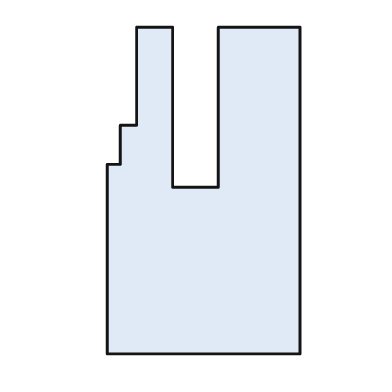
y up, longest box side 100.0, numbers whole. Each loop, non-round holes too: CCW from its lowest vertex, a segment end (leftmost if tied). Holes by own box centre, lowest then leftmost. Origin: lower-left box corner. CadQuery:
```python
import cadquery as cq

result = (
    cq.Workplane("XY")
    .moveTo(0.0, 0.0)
    .lineTo(59.0, 0.0)
    .lineTo(59.0, 100.0)
    .lineTo(34.0, 100.0)
    .lineTo(34.0, 51.0)
    .lineTo(20.0, 51.0)
    .lineTo(20.0, 100.0)
    .lineTo(9.0, 100.0)
    .lineTo(9.0, 70.0)
    .lineTo(4.0, 70.0)
    .lineTo(4.0, 58.0)
    .lineTo(0.0, 58.0)
    .close()
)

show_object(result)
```